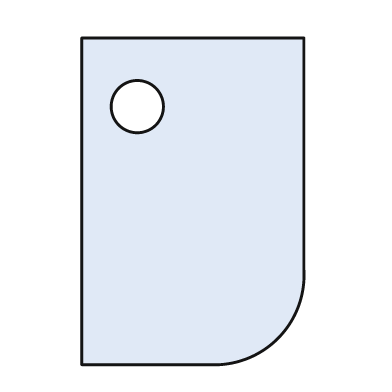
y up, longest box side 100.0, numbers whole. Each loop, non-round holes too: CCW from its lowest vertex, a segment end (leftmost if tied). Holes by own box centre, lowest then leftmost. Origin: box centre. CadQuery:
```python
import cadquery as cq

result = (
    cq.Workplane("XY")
    .moveTo(-34.0, -50.0)
    .lineTo(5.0, -50.0)
    .threePointArc((26.0, -42.0), (34.0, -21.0))
    .lineTo(34.0, 50.0)
    .lineTo(-34.0, 50.0)
    .close()
    .moveTo(-17.0, 29.0)
    .circle(8.0)
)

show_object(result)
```